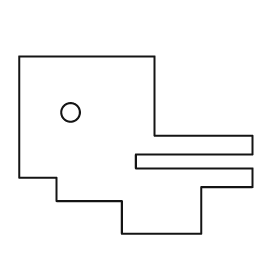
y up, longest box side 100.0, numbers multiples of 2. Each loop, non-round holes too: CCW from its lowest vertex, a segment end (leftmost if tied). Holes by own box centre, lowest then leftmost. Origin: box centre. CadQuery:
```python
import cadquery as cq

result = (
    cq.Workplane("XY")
    .moveTo(-6.0, -38.0)
    .lineTo(28.0, -38.0)
    .lineTo(28.0, -18.0)
    .lineTo(50.0, -18.0)
    .lineTo(50.0, -10.0)
    .lineTo(0.0, -10.0)
    .lineTo(0.0, -4.0)
    .lineTo(50.0, -4.0)
    .lineTo(50.0, 4.0)
    .lineTo(8.0, 4.0)
    .lineTo(8.0, 38.0)
    .lineTo(-50.0, 38.0)
    .lineTo(-50.0, -14.0)
    .lineTo(-34.0, -14.0)
    .lineTo(-34.0, -24.0)
    .lineTo(-6.0, -24.0)
    .close()
    .moveTo(-28.0, 14.0)
    .circle(4.0)
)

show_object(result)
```